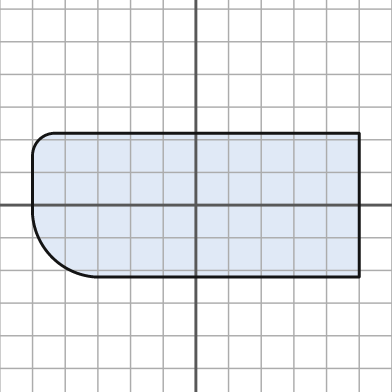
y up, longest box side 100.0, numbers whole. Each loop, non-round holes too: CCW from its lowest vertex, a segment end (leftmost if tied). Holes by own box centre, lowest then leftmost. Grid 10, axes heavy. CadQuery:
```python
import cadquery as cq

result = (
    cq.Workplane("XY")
    .moveTo(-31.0, -22.0)
    .lineTo(50.0, -22.0)
    .lineTo(50.0, 22.0)
    .lineTo(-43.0, 22.0)
    .threePointArc((-48.0, 20.0), (-50.0, 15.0))
    .lineTo(-50.0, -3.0)
    .threePointArc((-44.0, -16.0), (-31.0, -22.0))
    .close()
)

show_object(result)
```